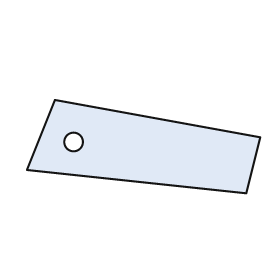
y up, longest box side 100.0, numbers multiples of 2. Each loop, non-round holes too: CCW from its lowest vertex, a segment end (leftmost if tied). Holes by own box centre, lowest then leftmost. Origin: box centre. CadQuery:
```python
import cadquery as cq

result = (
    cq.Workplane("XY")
    .moveTo(44.0, -20.0)
    .lineTo(50.0, 4.0)
    .lineTo(-38.0, 20.0)
    .lineTo(-50.0, -10.0)
    .close()
    .moveTo(-30.0, 2.0)
    .circle(4.0)
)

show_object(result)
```